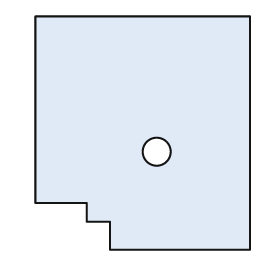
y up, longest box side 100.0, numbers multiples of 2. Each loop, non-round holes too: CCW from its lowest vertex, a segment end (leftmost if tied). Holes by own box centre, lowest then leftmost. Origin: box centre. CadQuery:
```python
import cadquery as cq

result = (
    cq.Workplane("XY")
    .moveTo(-14.0, -50.0)
    .lineTo(46.0, -50.0)
    .lineTo(46.0, 50.0)
    .lineTo(-46.0, 50.0)
    .lineTo(-46.0, -30.0)
    .lineTo(-24.0, -30.0)
    .lineTo(-24.0, -38.0)
    .lineTo(-14.0, -38.0)
    .close()
    .moveTo(6.0, -8.0)
    .circle(6.0)
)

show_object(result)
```